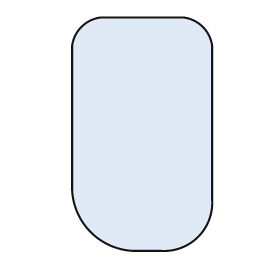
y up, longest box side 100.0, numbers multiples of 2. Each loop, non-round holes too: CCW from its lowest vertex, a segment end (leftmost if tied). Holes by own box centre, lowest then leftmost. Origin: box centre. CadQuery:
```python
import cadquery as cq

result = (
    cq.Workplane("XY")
    .moveTo(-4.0, -50.0)
    .lineTo(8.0, -50.0)
    .threePointArc((24.0, -44.0), (30.0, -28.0))
    .lineTo(30.0, 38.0)
    .threePointArc((26.0, 46.0), (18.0, 50.0))
    .lineTo(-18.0, 50.0)
    .threePointArc((-26.0, 46.0), (-30.0, 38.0))
    .lineTo(-30.0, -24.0)
    .threePointArc((-22.0, -42.0), (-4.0, -50.0))
    .close()
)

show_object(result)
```